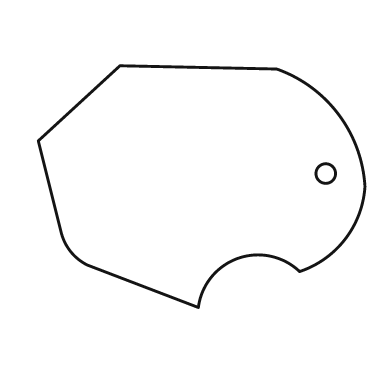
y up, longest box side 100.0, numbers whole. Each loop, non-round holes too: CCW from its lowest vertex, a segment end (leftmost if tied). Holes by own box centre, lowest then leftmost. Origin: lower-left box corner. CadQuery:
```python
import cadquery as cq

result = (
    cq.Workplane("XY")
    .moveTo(49.0, 0.0)
    .threePointArc((61.0, 15.0), (80.0, 11.0))
    .threePointArc((94.0, 21.0), (100.0, 37.0))
    .threePointArc((92.0, 59.0), (73.0, 73.0))
    .lineTo(25.0, 74.0)
    .lineTo(0.0, 51.0)
    .lineTo(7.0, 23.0)
    .threePointArc((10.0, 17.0), (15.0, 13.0))
    .close()
    .moveTo(88.0, 41.0)
    .circle(3.0)
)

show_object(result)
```